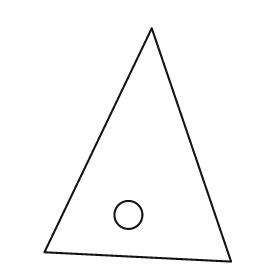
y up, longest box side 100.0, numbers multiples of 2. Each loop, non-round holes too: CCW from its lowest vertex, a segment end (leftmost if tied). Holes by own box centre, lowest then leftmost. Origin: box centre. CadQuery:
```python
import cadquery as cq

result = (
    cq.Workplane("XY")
    .moveTo(40.0, -50.0)
    .lineTo(6.0, 50.0)
    .lineTo(-40.0, -46.0)
    .close()
    .moveTo(-4.0, -30.0)
    .circle(6.0)
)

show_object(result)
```